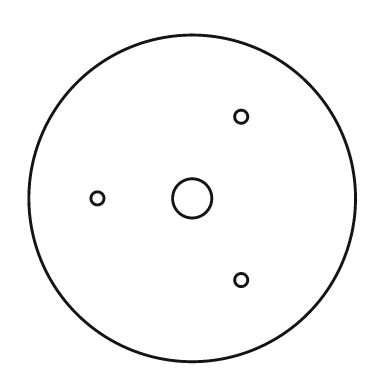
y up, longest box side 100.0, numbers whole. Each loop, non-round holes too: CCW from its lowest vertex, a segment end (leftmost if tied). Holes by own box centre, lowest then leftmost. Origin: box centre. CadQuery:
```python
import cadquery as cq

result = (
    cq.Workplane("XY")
    .moveTo(0.0, 0.0)
    .circle(50.0)
    .moveTo(15.0, -25.0)
    .circle(2.0)
    .moveTo(-29.0, 0.0)
    .circle(2.0)
    .moveTo(0.0, 0.0)
    .circle(6.0)
    .moveTo(15.0, 25.0)
    .circle(2.0)
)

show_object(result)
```